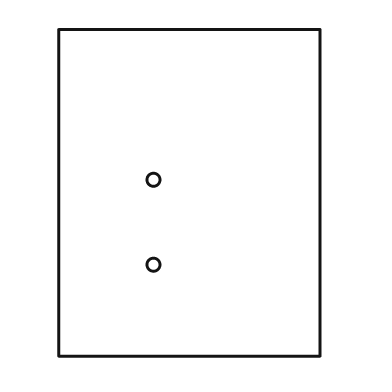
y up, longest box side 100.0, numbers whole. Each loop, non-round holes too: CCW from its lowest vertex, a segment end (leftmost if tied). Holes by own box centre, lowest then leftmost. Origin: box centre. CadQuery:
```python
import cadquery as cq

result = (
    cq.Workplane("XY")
    .moveTo(-40.0, -50.0)
    .lineTo(40.0, -50.0)
    .lineTo(40.0, 50.0)
    .lineTo(-40.0, 50.0)
    .close()
    .moveTo(-11.0, -22.0)
    .circle(2.0)
    .moveTo(-11.0, 4.0)
    .circle(2.0)
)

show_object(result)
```